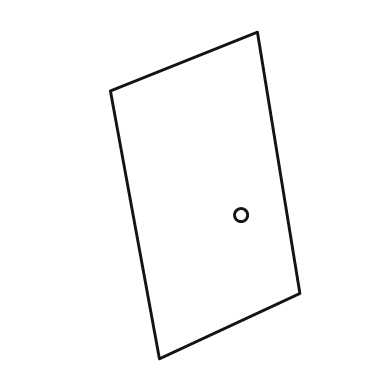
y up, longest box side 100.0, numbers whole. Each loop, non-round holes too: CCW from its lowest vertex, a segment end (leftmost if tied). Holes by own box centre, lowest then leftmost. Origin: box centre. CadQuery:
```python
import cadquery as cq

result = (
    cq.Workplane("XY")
    .moveTo(-14.0, -50.0)
    .lineTo(29.0, -30.0)
    .lineTo(16.0, 50.0)
    .lineTo(-29.0, 32.0)
    .close()
    .moveTo(11.0, -6.0)
    .circle(2.0)
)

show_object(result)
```